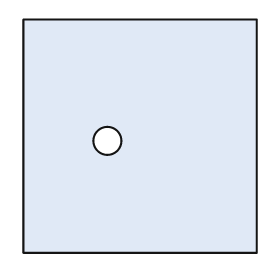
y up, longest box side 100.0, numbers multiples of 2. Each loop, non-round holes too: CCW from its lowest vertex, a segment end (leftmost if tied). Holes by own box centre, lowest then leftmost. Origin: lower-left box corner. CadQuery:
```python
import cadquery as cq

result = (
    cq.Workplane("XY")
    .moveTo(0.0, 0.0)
    .lineTo(100.0, 0.0)
    .lineTo(100.0, 100.0)
    .lineTo(0.0, 100.0)
    .close()
    .moveTo(36.0, 48.0)
    .circle(6.0)
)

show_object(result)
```